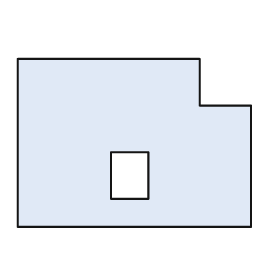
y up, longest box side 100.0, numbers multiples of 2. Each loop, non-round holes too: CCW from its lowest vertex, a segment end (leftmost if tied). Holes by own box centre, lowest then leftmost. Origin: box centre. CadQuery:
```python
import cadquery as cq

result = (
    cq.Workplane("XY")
    .moveTo(-50.0, -36.0)
    .lineTo(50.0, -36.0)
    .lineTo(50.0, 16.0)
    .lineTo(28.0, 16.0)
    .lineTo(28.0, 36.0)
    .lineTo(-50.0, 36.0)
    .close()
    .moveTo(-10.0, -24.0)
    .lineTo(6.0, -24.0)
    .lineTo(6.0, -4.0)
    .lineTo(-10.0, -4.0)
    .close()
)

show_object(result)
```